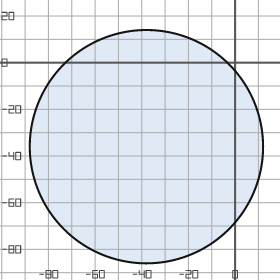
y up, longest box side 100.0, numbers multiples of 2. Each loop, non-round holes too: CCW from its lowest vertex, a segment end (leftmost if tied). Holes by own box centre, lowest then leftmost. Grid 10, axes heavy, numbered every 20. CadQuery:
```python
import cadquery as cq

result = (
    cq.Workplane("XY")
    .moveTo(-38.0, -36.0)
    .circle(50.0)
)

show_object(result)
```